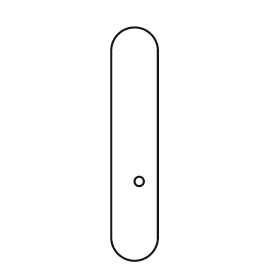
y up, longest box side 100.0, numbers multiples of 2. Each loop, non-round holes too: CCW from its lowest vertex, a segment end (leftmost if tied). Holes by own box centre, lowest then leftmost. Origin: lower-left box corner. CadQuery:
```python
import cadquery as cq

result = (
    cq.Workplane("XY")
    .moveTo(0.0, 10.0)
    .threePointArc((10.0, 0.0), (20.0, 10.0))
    .lineTo(20.0, 90.0)
    .threePointArc((10.0, 100.0), (0.0, 90.0))
    .close()
    .moveTo(12.0, 34.0)
    .circle(2.0)
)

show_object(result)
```